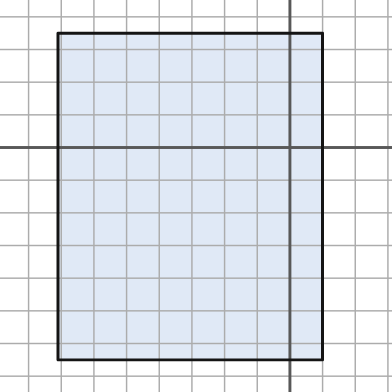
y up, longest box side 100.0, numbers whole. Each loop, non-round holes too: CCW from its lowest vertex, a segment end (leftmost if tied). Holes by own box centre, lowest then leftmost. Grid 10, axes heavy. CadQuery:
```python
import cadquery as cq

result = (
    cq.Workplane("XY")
    .moveTo(-71.0, -65.0)
    .lineTo(10.0, -65.0)
    .lineTo(10.0, 35.0)
    .lineTo(-71.0, 35.0)
    .close()
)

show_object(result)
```